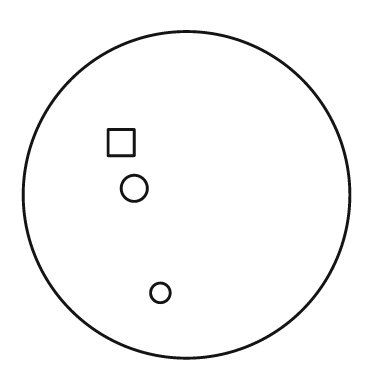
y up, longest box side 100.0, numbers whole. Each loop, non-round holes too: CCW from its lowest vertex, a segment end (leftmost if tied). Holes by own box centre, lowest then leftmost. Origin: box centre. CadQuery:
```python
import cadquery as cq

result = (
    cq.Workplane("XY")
    .moveTo(0.0, 0.0)
    .circle(50.0)
    .moveTo(-8.0, -30.0)
    .circle(3.0)
    .moveTo(-16.0, 2.0)
    .circle(4.0)
    .moveTo(-24.0, 12.0)
    .lineTo(-16.0, 12.0)
    .lineTo(-16.0, 20.0)
    .lineTo(-24.0, 20.0)
    .close()
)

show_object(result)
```